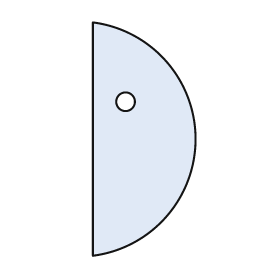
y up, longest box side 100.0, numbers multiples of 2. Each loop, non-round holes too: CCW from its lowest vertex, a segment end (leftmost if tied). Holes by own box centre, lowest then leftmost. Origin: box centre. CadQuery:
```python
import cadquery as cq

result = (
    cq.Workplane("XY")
    .moveTo(-22.0, -50.0)
    .threePointArc((22.0, 0.0), (-22.0, 50.0))
    .close()
    .moveTo(-8.0, 16.0)
    .circle(4.0)
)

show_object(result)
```